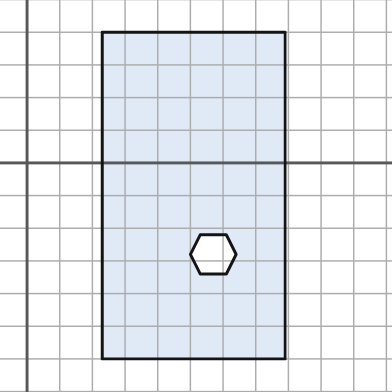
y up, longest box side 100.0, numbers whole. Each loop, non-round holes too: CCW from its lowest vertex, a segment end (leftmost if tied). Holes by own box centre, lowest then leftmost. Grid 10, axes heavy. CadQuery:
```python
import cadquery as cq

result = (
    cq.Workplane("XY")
    .moveTo(23.0, -60.0)
    .lineTo(79.0, -60.0)
    .lineTo(79.0, 40.0)
    .lineTo(23.0, 40.0)
    .close()
    .moveTo(53.0, -34.0)
    .lineTo(61.0, -34.0)
    .lineTo(64.0, -28.0)
    .lineTo(61.0, -22.0)
    .lineTo(53.0, -22.0)
    .lineTo(50.0, -28.0)
    .close()
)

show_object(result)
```